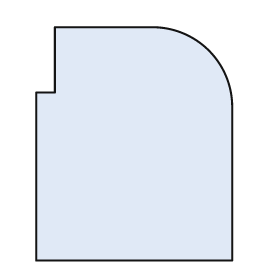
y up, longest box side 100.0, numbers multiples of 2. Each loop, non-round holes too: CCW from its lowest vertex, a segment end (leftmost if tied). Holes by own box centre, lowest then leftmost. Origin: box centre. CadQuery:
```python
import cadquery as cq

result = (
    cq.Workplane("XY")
    .moveTo(-42.0, -50.0)
    .lineTo(42.0, -50.0)
    .lineTo(42.0, 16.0)
    .threePointArc((32.0, 40.0), (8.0, 50.0))
    .lineTo(-34.0, 50.0)
    .lineTo(-34.0, 22.0)
    .lineTo(-42.0, 22.0)
    .close()
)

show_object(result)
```